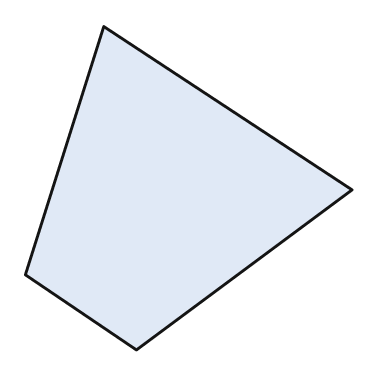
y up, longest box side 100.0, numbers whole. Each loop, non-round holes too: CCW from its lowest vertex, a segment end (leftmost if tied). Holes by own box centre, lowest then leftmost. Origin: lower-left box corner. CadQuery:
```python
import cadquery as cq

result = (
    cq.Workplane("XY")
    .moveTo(34.0, 0.0)
    .lineTo(100.0, 49.0)
    .lineTo(24.0, 99.0)
    .lineTo(0.0, 23.0)
    .close()
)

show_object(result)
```